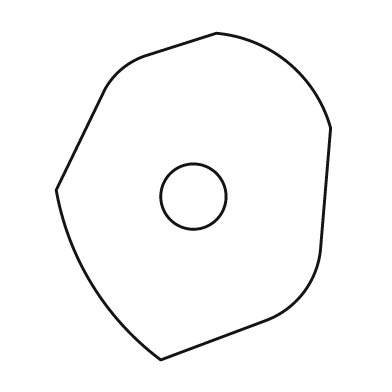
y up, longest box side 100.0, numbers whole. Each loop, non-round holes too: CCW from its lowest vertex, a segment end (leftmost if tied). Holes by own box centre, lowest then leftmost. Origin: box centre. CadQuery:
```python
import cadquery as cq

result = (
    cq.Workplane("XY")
    .moveTo(-10.0, -50.0)
    .lineTo(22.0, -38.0)
    .threePointArc((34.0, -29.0), (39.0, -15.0))
    .lineTo(42.0, 21.0)
    .threePointArc((29.0, 41.0), (7.0, 50.0))
    .lineTo(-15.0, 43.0)
    .threePointArc((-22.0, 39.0), (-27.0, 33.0))
    .lineTo(-42.0, 2.0)
    .threePointArc((-31.0, -27.0), (-10.0, -50.0))
    .close()
    .moveTo(0.0, 0.0)
    .circle(10.0)
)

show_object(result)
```